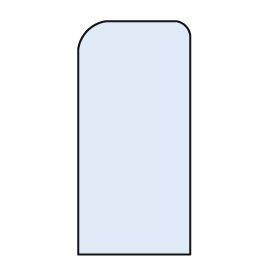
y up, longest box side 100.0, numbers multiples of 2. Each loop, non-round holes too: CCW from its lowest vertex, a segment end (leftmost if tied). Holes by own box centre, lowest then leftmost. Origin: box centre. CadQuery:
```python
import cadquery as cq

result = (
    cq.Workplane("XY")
    .moveTo(-24.0, -50.0)
    .lineTo(24.0, -50.0)
    .lineTo(24.0, 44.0)
    .threePointArc((22.0, 48.0), (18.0, 50.0))
    .lineTo(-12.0, 50.0)
    .threePointArc((-20.0, 46.0), (-24.0, 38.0))
    .close()
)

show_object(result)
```